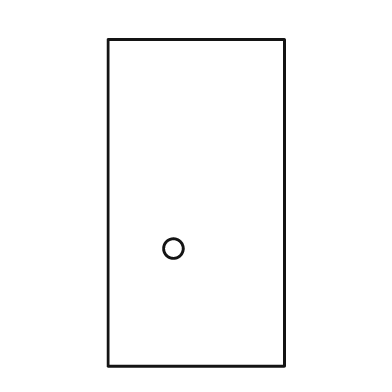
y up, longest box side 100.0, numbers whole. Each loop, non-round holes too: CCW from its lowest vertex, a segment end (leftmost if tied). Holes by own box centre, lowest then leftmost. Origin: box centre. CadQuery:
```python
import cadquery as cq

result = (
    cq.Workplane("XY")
    .moveTo(-27.0, -50.0)
    .lineTo(27.0, -50.0)
    .lineTo(27.0, 50.0)
    .lineTo(-27.0, 50.0)
    .close()
    .moveTo(-7.0, -14.0)
    .circle(3.0)
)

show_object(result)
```